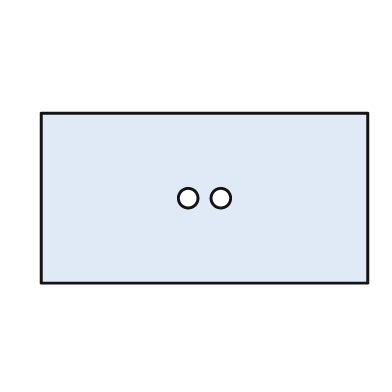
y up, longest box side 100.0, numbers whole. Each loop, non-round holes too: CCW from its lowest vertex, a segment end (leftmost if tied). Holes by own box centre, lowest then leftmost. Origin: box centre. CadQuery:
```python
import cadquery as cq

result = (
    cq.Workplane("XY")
    .moveTo(-50.0, -26.0)
    .lineTo(50.0, -26.0)
    .lineTo(50.0, 26.0)
    .lineTo(-50.0, 26.0)
    .close()
    .moveTo(-5.0, 0.0)
    .circle(3.0)
    .moveTo(5.0, 0.0)
    .circle(3.0)
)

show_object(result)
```